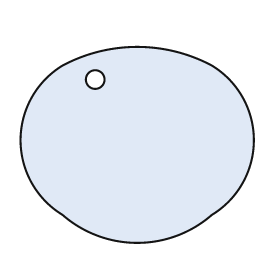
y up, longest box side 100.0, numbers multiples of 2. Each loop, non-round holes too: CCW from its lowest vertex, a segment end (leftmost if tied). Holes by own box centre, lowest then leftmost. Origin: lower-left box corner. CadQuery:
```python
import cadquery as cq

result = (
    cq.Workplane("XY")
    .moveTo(18.0, 12.0)
    .threePointArc((50.0, 0.0), (82.0, 12.0))
    .threePointArc((100.0, 44.0), (82.0, 76.0))
    .threePointArc((50.0, 84.0), (18.0, 76.0))
    .threePointArc((0.0, 44.0), (18.0, 12.0))
    .close()
    .moveTo(32.0, 70.0)
    .circle(4.0)
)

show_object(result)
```